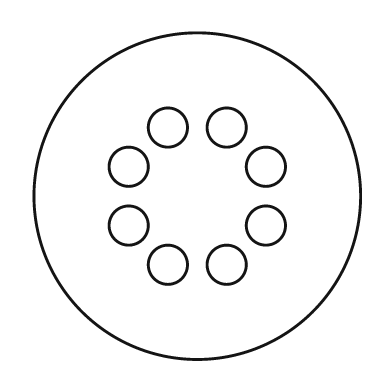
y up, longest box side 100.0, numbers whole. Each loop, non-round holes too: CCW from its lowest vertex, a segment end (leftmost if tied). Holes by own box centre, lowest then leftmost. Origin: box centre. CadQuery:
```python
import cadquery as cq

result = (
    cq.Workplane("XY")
    .moveTo(0.0, 0.0)
    .circle(50.0)
    .moveTo(-9.0, -21.0)
    .circle(6.0)
    .moveTo(9.0, -21.0)
    .circle(6.0)
    .moveTo(-21.0, -9.0)
    .circle(6.0)
    .moveTo(21.0, -9.0)
    .circle(6.0)
    .moveTo(-21.0, 9.0)
    .circle(6.0)
    .moveTo(21.0, 9.0)
    .circle(6.0)
    .moveTo(-9.0, 21.0)
    .circle(6.0)
    .moveTo(9.0, 21.0)
    .circle(6.0)
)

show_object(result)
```